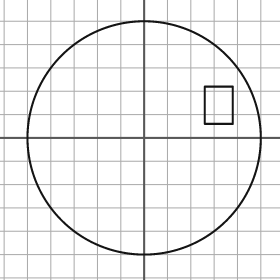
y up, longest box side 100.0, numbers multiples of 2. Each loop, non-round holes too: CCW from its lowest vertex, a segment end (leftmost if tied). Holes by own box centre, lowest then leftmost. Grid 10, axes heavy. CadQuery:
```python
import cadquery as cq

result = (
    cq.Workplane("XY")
    .moveTo(0.0, 0.0)
    .circle(50.0)
    .moveTo(26.0, 6.0)
    .lineTo(38.0, 6.0)
    .lineTo(38.0, 22.0)
    .lineTo(26.0, 22.0)
    .close()
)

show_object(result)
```